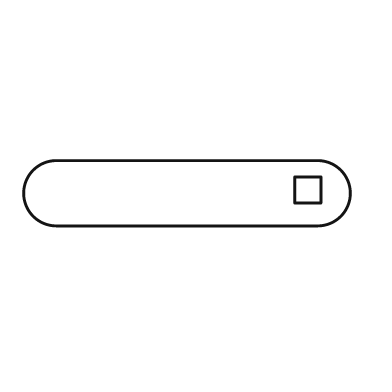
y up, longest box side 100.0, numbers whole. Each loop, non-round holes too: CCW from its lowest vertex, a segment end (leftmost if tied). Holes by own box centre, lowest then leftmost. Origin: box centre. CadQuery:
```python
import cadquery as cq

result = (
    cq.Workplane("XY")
    .moveTo(-40.0, -10.0)
    .lineTo(40.0, -10.0)
    .threePointArc((50.0, 0.0), (40.0, 10.0))
    .lineTo(-40.0, 10.0)
    .threePointArc((-50.0, 0.0), (-40.0, -10.0))
    .close()
    .moveTo(33.0, -3.0)
    .lineTo(41.0, -3.0)
    .lineTo(41.0, 5.0)
    .lineTo(33.0, 5.0)
    .close()
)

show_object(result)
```